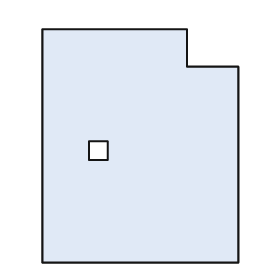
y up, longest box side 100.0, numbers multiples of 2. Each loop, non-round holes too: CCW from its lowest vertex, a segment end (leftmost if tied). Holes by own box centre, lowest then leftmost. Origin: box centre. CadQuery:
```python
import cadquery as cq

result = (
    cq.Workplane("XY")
    .moveTo(-42.0, -50.0)
    .lineTo(42.0, -50.0)
    .lineTo(42.0, 34.0)
    .lineTo(20.0, 34.0)
    .lineTo(20.0, 50.0)
    .lineTo(-42.0, 50.0)
    .close()
    .moveTo(-22.0, -6.0)
    .lineTo(-14.0, -6.0)
    .lineTo(-14.0, 2.0)
    .lineTo(-22.0, 2.0)
    .close()
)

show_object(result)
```